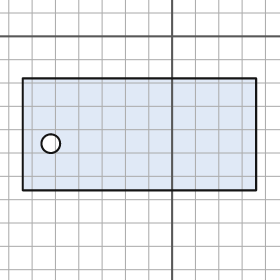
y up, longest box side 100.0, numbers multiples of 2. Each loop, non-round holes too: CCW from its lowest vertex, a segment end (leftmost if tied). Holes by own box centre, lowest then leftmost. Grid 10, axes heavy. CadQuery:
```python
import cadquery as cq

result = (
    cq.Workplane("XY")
    .moveTo(-64.0, -66.0)
    .lineTo(36.0, -66.0)
    .lineTo(36.0, -18.0)
    .lineTo(-64.0, -18.0)
    .close()
    .moveTo(-52.0, -46.0)
    .circle(4.0)
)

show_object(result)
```